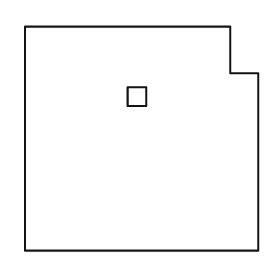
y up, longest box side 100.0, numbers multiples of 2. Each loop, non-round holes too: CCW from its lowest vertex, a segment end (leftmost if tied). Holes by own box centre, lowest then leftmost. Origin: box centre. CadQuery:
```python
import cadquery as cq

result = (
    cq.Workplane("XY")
    .moveTo(-50.0, -48.0)
    .lineTo(50.0, -48.0)
    .lineTo(50.0, 28.0)
    .lineTo(38.0, 28.0)
    .lineTo(38.0, 48.0)
    .lineTo(-50.0, 48.0)
    .close()
    .moveTo(-6.0, 14.0)
    .lineTo(2.0, 14.0)
    .lineTo(2.0, 22.0)
    .lineTo(-6.0, 22.0)
    .close()
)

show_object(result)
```